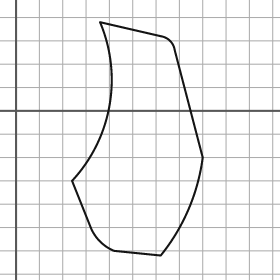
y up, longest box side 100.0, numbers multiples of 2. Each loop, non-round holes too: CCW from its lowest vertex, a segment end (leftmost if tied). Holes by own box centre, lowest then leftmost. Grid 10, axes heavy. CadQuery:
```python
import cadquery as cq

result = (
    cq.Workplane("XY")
    .moveTo(62.0, -62.0)
    .threePointArc((74.0, -42.0), (80.0, -20.0))
    .lineTo(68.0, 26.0)
    .threePointArc((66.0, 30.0), (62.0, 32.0))
    .lineTo(36.0, 38.0)
    .threePointArc((40.0, 2.0), (24.0, -30.0))
    .lineTo(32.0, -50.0)
    .threePointArc((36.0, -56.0), (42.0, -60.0))
    .close()
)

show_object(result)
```